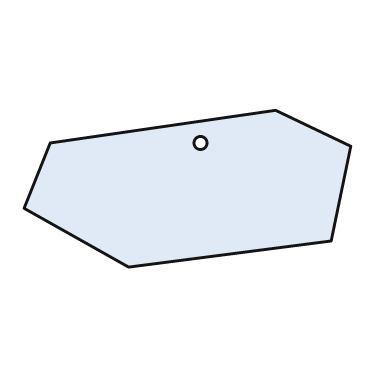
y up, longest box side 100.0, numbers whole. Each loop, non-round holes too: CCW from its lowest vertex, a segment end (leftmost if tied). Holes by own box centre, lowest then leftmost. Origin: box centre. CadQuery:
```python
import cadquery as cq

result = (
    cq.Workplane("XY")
    .moveTo(-18.0, -24.0)
    .lineTo(44.0, -16.0)
    .lineTo(50.0, 13.0)
    .lineTo(27.0, 24.0)
    .lineTo(-42.0, 14.0)
    .lineTo(-50.0, -6.0)
    .close()
    .moveTo(4.0, 14.0)
    .circle(2.0)
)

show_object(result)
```